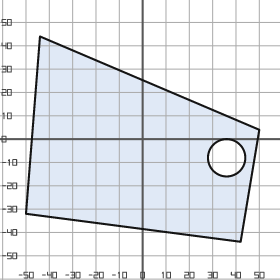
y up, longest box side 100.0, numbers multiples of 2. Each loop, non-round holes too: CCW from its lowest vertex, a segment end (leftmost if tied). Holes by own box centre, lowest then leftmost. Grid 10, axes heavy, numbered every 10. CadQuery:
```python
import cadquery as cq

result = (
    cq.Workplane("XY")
    .moveTo(42.0, -44.0)
    .lineTo(50.0, 4.0)
    .lineTo(-44.0, 44.0)
    .lineTo(-50.0, -32.0)
    .close()
    .moveTo(36.0, -8.0)
    .circle(8.0)
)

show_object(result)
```